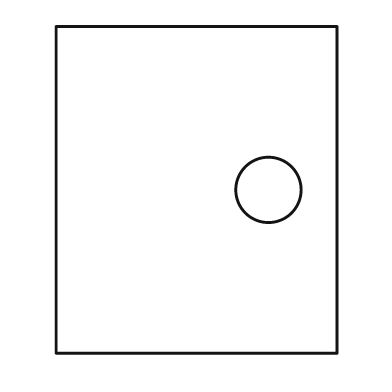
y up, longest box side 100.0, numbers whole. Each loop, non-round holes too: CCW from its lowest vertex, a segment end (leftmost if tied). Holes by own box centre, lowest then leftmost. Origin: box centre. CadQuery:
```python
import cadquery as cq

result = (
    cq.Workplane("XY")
    .moveTo(-43.0, -50.0)
    .lineTo(43.0, -50.0)
    .lineTo(43.0, 50.0)
    .lineTo(-43.0, 50.0)
    .close()
    .moveTo(22.0, 0.0)
    .circle(10.0)
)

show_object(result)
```